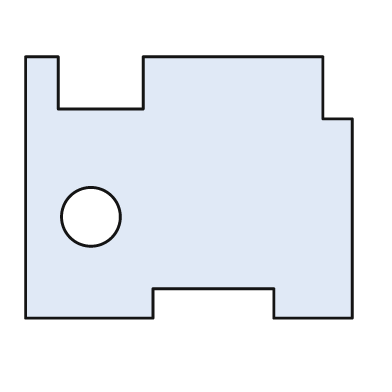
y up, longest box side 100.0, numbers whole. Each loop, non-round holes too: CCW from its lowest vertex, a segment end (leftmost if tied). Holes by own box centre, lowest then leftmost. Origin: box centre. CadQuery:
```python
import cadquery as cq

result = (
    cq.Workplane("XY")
    .moveTo(-50.0, -40.0)
    .lineTo(-11.0, -40.0)
    .lineTo(-11.0, -31.0)
    .lineTo(26.0, -31.0)
    .lineTo(26.0, -40.0)
    .lineTo(50.0, -40.0)
    .lineTo(50.0, 21.0)
    .lineTo(41.0, 21.0)
    .lineTo(41.0, 40.0)
    .lineTo(-14.0, 40.0)
    .lineTo(-14.0, 24.0)
    .lineTo(-40.0, 24.0)
    .lineTo(-40.0, 40.0)
    .lineTo(-50.0, 40.0)
    .close()
    .moveTo(-30.0, -9.0)
    .circle(9.0)
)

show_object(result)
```